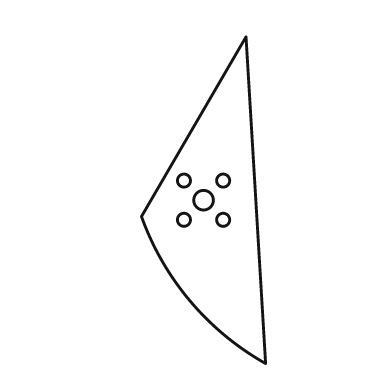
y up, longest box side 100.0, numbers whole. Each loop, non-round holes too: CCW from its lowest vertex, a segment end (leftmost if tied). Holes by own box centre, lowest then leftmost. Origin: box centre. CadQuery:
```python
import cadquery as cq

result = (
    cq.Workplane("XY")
    .moveTo(19.0, -50.0)
    .lineTo(13.0, 50.0)
    .lineTo(-19.0, -5.0)
    .threePointArc((-4.0, -31.0), (19.0, -50.0))
    .close()
    .moveTo(-6.0, -6.0)
    .circle(2.0)
    .moveTo(6.0, -6.0)
    .circle(2.0)
    .moveTo(0.0, 0.0)
    .circle(3.0)
    .moveTo(-6.0, 6.0)
    .circle(2.0)
    .moveTo(6.0, 6.0)
    .circle(2.0)
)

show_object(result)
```